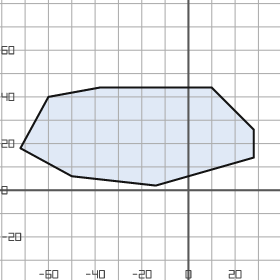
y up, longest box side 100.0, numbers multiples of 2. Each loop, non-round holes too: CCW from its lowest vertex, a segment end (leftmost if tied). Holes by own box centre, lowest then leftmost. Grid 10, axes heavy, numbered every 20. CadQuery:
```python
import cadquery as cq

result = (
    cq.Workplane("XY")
    .moveTo(-14.0, 2.0)
    .lineTo(28.0, 14.0)
    .lineTo(28.0, 26.0)
    .lineTo(10.0, 44.0)
    .lineTo(-38.0, 44.0)
    .lineTo(-60.0, 40.0)
    .lineTo(-72.0, 18.0)
    .lineTo(-50.0, 6.0)
    .close()
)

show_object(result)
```